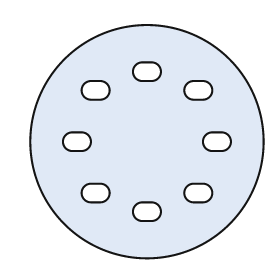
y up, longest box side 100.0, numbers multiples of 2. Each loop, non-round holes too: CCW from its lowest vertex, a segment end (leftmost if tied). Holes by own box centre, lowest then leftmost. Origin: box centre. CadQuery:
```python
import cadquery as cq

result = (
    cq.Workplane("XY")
    .moveTo(0.0, 0.0)
    .circle(50.0)
    .moveTo(-2.0, -34.0)
    .lineTo(2.0, -34.0)
    .threePointArc((6.0, -30.0), (2.0, -26.0))
    .lineTo(-2.0, -26.0)
    .threePointArc((-6.0, -30.0), (-2.0, -34.0))
    .close()
    .moveTo(-24.0, -26.0)
    .lineTo(-20.0, -26.0)
    .threePointArc((-16.0, -22.0), (-20.0, -18.0))
    .lineTo(-24.0, -18.0)
    .threePointArc((-28.0, -22.0), (-24.0, -26.0))
    .close()
    .moveTo(20.0, -26.0)
    .lineTo(24.0, -26.0)
    .threePointArc((28.0, -22.0), (24.0, -18.0))
    .lineTo(20.0, -18.0)
    .threePointArc((16.0, -22.0), (20.0, -26.0))
    .close()
    .moveTo(-32.0, -4.0)
    .lineTo(-28.0, -4.0)
    .threePointArc((-24.0, 0.0), (-28.0, 4.0))
    .lineTo(-32.0, 4.0)
    .threePointArc((-36.0, 0.0), (-32.0, -4.0))
    .close()
    .moveTo(28.0, -4.0)
    .lineTo(32.0, -4.0)
    .threePointArc((36.0, 0.0), (32.0, 4.0))
    .lineTo(28.0, 4.0)
    .threePointArc((24.0, 0.0), (28.0, -4.0))
    .close()
    .moveTo(-24.0, 18.0)
    .lineTo(-20.0, 18.0)
    .threePointArc((-16.0, 22.0), (-20.0, 26.0))
    .lineTo(-24.0, 26.0)
    .threePointArc((-28.0, 22.0), (-24.0, 18.0))
    .close()
    .moveTo(20.0, 18.0)
    .lineTo(24.0, 18.0)
    .threePointArc((28.0, 22.0), (24.0, 26.0))
    .lineTo(20.0, 26.0)
    .threePointArc((16.0, 22.0), (20.0, 18.0))
    .close()
    .moveTo(-2.0, 26.0)
    .lineTo(2.0, 26.0)
    .threePointArc((6.0, 30.0), (2.0, 34.0))
    .lineTo(-2.0, 34.0)
    .threePointArc((-6.0, 30.0), (-2.0, 26.0))
    .close()
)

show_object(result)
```